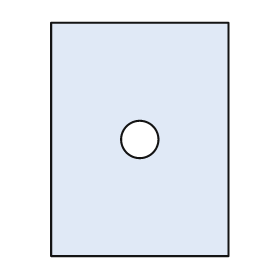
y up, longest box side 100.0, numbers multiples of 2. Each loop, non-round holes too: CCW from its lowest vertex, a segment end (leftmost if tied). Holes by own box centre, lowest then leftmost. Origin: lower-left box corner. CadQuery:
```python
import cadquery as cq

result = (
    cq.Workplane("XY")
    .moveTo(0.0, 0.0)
    .lineTo(76.0, 0.0)
    .lineTo(76.0, 100.0)
    .lineTo(0.0, 100.0)
    .close()
    .moveTo(38.0, 50.0)
    .circle(8.0)
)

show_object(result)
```